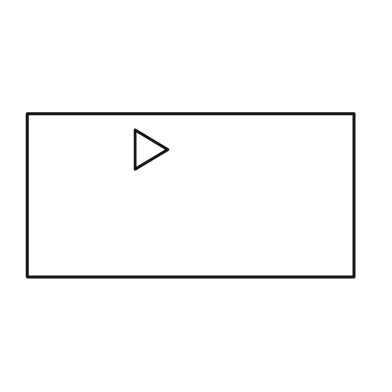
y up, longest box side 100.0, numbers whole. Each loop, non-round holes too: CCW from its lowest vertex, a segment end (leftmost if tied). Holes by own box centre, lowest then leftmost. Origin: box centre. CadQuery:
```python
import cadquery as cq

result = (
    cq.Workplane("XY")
    .moveTo(-50.0, -25.0)
    .lineTo(50.0, -25.0)
    .lineTo(50.0, 25.0)
    .lineTo(-50.0, 25.0)
    .close()
    .moveTo(-17.0, 8.0)
    .lineTo(-7.0, 14.0)
    .lineTo(-17.0, 20.0)
    .close()
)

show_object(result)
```